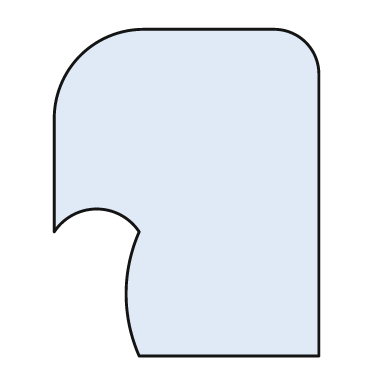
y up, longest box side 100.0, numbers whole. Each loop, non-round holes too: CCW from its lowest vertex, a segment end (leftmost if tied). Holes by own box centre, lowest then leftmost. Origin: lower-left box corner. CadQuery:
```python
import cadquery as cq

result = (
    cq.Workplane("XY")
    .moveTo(26.0, 0.0)
    .lineTo(81.0, 0.0)
    .lineTo(81.0, 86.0)
    .threePointArc((77.0, 96.0), (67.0, 100.0))
    .lineTo(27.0, 100.0)
    .threePointArc((8.0, 92.0), (0.0, 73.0))
    .lineTo(0.0, 38.0)
    .threePointArc((13.0, 45.0), (26.0, 38.0))
    .threePointArc((22.0, 19.0), (26.0, 0.0))
    .close()
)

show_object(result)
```